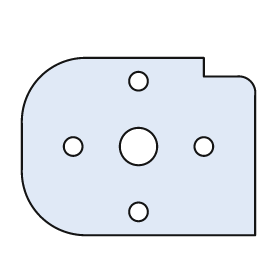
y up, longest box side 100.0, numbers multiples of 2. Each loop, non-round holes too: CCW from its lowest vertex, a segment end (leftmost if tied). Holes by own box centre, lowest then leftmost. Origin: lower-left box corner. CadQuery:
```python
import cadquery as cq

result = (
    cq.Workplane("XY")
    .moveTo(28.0, 0.0)
    .lineTo(100.0, 0.0)
    .lineTo(100.0, 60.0)
    .threePointArc((98.0, 66.0), (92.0, 68.0))
    .lineTo(78.0, 68.0)
    .lineTo(78.0, 76.0)
    .lineTo(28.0, 76.0)
    .threePointArc((8.0, 68.0), (0.0, 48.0))
    .lineTo(0.0, 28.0)
    .threePointArc((8.0, 8.0), (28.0, 0.0))
    .close()
    .moveTo(50.0, 10.0)
    .circle(4.0)
    .moveTo(22.0, 38.0)
    .circle(4.0)
    .moveTo(50.0, 38.0)
    .circle(8.0)
    .moveTo(78.0, 38.0)
    .circle(4.0)
    .moveTo(50.0, 66.0)
    .circle(4.0)
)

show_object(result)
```